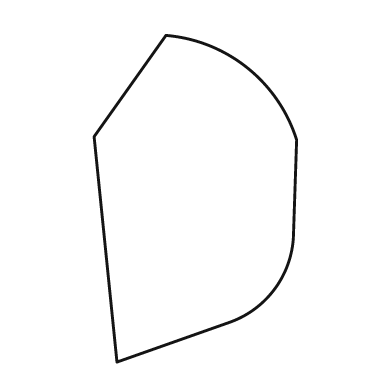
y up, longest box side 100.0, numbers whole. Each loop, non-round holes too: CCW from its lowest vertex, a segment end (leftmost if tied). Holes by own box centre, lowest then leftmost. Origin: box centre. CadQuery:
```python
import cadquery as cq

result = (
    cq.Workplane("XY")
    .moveTo(-24.0, -50.0)
    .lineTo(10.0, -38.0)
    .threePointArc((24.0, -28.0), (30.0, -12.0))
    .lineTo(31.0, 18.0)
    .threePointArc((16.0, 40.0), (-9.0, 50.0))
    .lineTo(-31.0, 19.0)
    .close()
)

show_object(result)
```